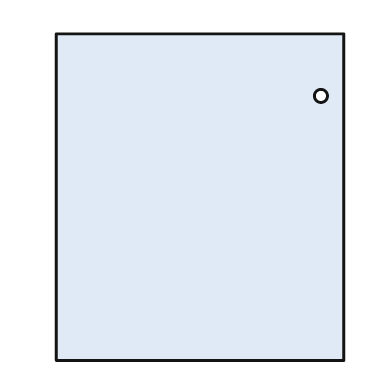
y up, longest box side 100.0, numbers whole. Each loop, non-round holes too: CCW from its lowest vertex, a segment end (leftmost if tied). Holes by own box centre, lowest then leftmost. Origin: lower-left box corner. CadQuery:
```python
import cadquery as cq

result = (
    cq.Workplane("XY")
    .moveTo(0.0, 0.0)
    .lineTo(88.0, 0.0)
    .lineTo(88.0, 100.0)
    .lineTo(0.0, 100.0)
    .close()
    .moveTo(81.0, 81.0)
    .circle(2.0)
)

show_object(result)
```